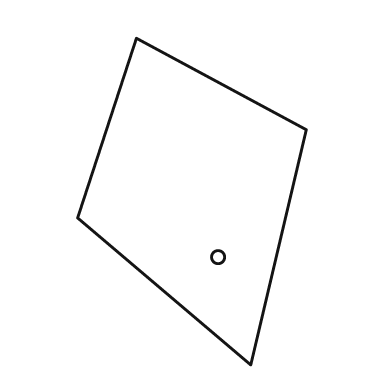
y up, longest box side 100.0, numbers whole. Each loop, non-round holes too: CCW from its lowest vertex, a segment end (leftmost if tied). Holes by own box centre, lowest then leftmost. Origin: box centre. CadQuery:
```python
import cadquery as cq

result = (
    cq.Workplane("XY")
    .moveTo(18.0, -50.0)
    .lineTo(35.0, 22.0)
    .lineTo(-17.0, 50.0)
    .lineTo(-35.0, -5.0)
    .close()
    .moveTo(8.0, -17.0)
    .circle(2.0)
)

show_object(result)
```